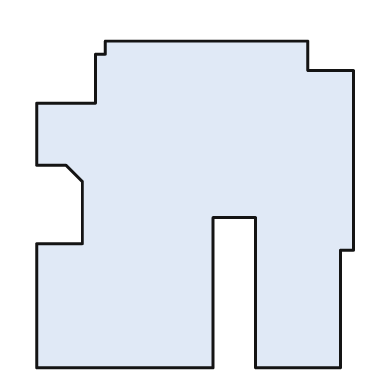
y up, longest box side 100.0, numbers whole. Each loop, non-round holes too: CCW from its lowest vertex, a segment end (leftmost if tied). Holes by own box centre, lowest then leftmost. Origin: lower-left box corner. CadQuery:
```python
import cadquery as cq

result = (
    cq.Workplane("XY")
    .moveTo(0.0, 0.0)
    .lineTo(54.0, 0.0)
    .lineTo(54.0, 46.0)
    .lineTo(67.0, 46.0)
    .lineTo(67.0, 0.0)
    .lineTo(93.0, 0.0)
    .lineTo(93.0, 36.0)
    .lineTo(97.0, 36.0)
    .lineTo(97.0, 91.0)
    .lineTo(83.0, 91.0)
    .lineTo(83.0, 100.0)
    .lineTo(21.0, 100.0)
    .lineTo(21.0, 96.0)
    .lineTo(18.0, 96.0)
    .lineTo(18.0, 81.0)
    .lineTo(0.0, 81.0)
    .lineTo(0.0, 62.0)
    .lineTo(9.0, 62.0)
    .lineTo(14.0, 57.0)
    .lineTo(14.0, 38.0)
    .lineTo(0.0, 38.0)
    .close()
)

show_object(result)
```